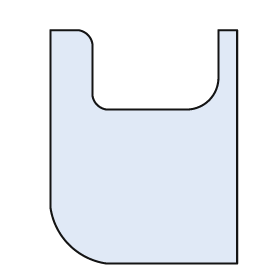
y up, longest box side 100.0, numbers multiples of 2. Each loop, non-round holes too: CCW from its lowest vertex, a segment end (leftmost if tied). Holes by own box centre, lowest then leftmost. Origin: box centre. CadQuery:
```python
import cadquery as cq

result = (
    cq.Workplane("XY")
    .moveTo(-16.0, -50.0)
    .lineTo(40.0, -50.0)
    .lineTo(40.0, 50.0)
    .lineTo(32.0, 50.0)
    .lineTo(32.0, 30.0)
    .threePointArc((28.0, 20.0), (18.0, 16.0))
    .lineTo(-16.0, 16.0)
    .threePointArc((-20.0, 18.0), (-22.0, 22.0))
    .lineTo(-22.0, 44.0)
    .threePointArc((-24.0, 48.0), (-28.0, 50.0))
    .lineTo(-40.0, 50.0)
    .lineTo(-40.0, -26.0)
    .threePointArc((-32.0, -42.0), (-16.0, -50.0))
    .close()
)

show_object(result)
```